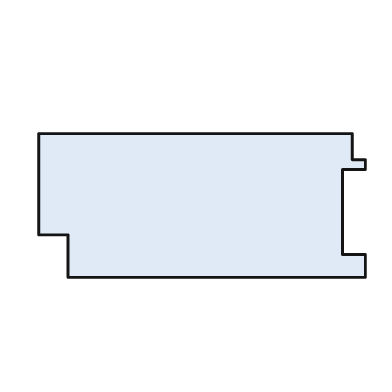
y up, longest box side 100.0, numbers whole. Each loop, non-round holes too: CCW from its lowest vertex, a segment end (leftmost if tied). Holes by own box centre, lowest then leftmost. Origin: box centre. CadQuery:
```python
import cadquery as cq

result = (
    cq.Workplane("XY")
    .moveTo(-41.0, -22.0)
    .lineTo(50.0, -22.0)
    .lineTo(50.0, -15.0)
    .lineTo(43.0, -15.0)
    .lineTo(43.0, 11.0)
    .lineTo(50.0, 11.0)
    .lineTo(50.0, 14.0)
    .lineTo(46.0, 14.0)
    .lineTo(46.0, 22.0)
    .lineTo(-50.0, 22.0)
    .lineTo(-50.0, -9.0)
    .lineTo(-41.0, -9.0)
    .close()
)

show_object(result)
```